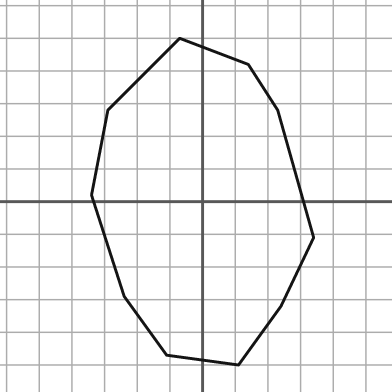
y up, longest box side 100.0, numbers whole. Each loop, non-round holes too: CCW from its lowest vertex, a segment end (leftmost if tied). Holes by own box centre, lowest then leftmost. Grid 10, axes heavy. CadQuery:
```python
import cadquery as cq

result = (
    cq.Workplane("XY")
    .moveTo(11.0, -50.0)
    .lineTo(24.0, -32.0)
    .lineTo(34.0, -11.0)
    .lineTo(23.0, 28.0)
    .lineTo(14.0, 42.0)
    .lineTo(-7.0, 50.0)
    .lineTo(-29.0, 28.0)
    .lineTo(-34.0, 2.0)
    .lineTo(-24.0, -29.0)
    .lineTo(-11.0, -47.0)
    .close()
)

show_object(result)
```